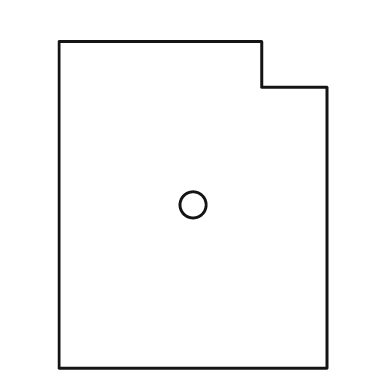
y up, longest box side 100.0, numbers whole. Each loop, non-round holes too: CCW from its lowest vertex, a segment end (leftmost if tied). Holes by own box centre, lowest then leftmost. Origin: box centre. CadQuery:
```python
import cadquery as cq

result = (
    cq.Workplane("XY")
    .moveTo(-41.0, -50.0)
    .lineTo(41.0, -50.0)
    .lineTo(41.0, 36.0)
    .lineTo(21.0, 36.0)
    .lineTo(21.0, 50.0)
    .lineTo(-41.0, 50.0)
    .close()
    .moveTo(0.0, 0.0)
    .circle(4.0)
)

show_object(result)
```